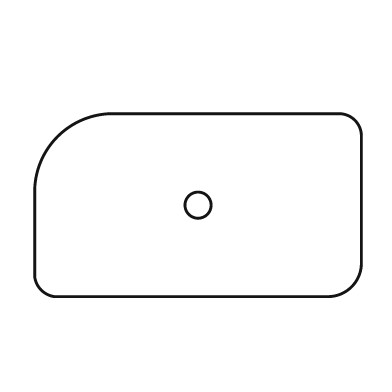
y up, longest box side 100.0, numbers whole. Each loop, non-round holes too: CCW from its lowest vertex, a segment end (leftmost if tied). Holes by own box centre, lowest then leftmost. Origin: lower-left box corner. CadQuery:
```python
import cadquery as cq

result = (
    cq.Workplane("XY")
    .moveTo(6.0, 0.0)
    .lineTo(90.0, 0.0)
    .threePointArc((97.0, 3.0), (100.0, 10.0))
    .lineTo(100.0, 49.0)
    .threePointArc((98.0, 54.0), (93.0, 56.0))
    .lineTo(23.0, 56.0)
    .threePointArc((7.0, 49.0), (0.0, 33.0))
    .lineTo(0.0, 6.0)
    .threePointArc((2.0, 2.0), (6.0, 0.0))
    .close()
    .moveTo(50.0, 28.0)
    .circle(4.0)
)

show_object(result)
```